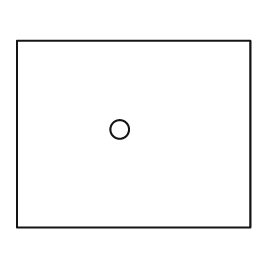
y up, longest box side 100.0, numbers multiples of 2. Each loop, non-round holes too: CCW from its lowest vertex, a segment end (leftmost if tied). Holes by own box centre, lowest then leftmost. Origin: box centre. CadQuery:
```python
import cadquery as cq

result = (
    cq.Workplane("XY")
    .moveTo(-50.0, -40.0)
    .lineTo(50.0, -40.0)
    .lineTo(50.0, 40.0)
    .lineTo(-50.0, 40.0)
    .close()
    .moveTo(-6.0, 2.0)
    .circle(4.0)
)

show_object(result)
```